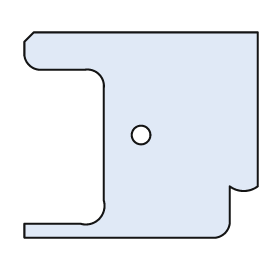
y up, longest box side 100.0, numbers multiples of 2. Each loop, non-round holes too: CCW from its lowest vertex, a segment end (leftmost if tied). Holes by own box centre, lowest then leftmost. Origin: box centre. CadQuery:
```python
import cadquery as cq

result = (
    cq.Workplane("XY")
    .moveTo(-50.0, -44.0)
    .lineTo(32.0, -44.0)
    .threePointArc((36.0, -42.0), (38.0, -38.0))
    .lineTo(38.0, -22.0)
    .threePointArc((44.0, -24.0), (50.0, -22.0))
    .lineTo(50.0, 44.0)
    .lineTo(-46.0, 44.0)
    .lineTo(-50.0, 40.0)
    .lineTo(-50.0, 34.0)
    .threePointArc((-48.0, 30.0), (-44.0, 28.0))
    .lineTo(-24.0, 28.0)
    .threePointArc((-18.0, 26.0), (-16.0, 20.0))
    .lineTo(-16.0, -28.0)
    .threePointArc((-18.0, -36.0), (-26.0, -38.0))
    .lineTo(-50.0, -38.0)
    .close()
    .moveTo(0.0, 0.0)
    .circle(4.0)
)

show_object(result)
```